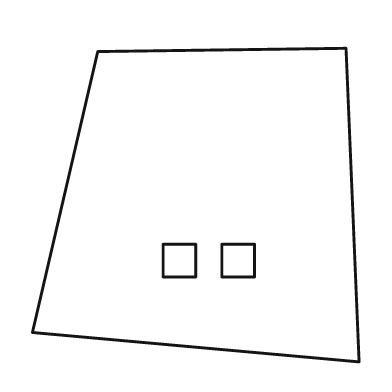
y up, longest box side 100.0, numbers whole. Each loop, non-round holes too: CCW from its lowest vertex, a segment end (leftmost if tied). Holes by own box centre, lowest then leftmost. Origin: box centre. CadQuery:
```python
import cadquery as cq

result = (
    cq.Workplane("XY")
    .moveTo(50.0, -48.0)
    .lineTo(46.0, 48.0)
    .lineTo(-30.0, 47.0)
    .lineTo(-50.0, -39.0)
    .close()
    .moveTo(-10.0, -22.0)
    .lineTo(0.0, -22.0)
    .lineTo(0.0, -12.0)
    .lineTo(-10.0, -12.0)
    .close()
    .moveTo(8.0, -22.0)
    .lineTo(18.0, -22.0)
    .lineTo(18.0, -12.0)
    .lineTo(8.0, -12.0)
    .close()
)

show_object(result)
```